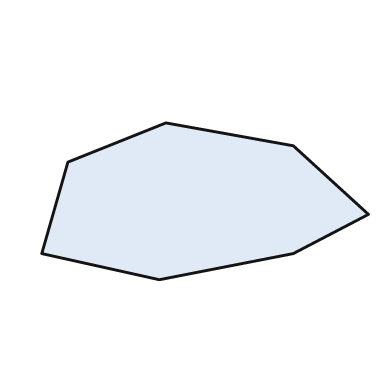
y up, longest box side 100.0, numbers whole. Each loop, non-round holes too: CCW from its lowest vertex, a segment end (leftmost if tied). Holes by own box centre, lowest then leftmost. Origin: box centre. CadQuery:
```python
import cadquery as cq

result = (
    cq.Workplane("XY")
    .moveTo(-14.0, -24.0)
    .lineTo(27.0, -16.0)
    .lineTo(50.0, -4.0)
    .lineTo(27.0, 17.0)
    .lineTo(-12.0, 24.0)
    .lineTo(-42.0, 12.0)
    .lineTo(-50.0, -16.0)
    .close()
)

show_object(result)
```